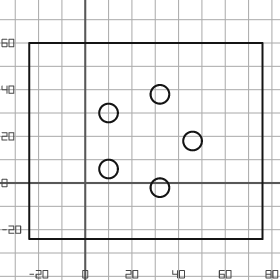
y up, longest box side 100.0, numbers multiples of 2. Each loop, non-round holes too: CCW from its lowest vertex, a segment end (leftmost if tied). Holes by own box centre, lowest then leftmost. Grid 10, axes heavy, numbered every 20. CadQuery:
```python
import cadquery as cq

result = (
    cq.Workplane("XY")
    .moveTo(-24.0, -24.0)
    .lineTo(76.0, -24.0)
    .lineTo(76.0, 60.0)
    .lineTo(-24.0, 60.0)
    .close()
    .moveTo(32.0, -2.0)
    .circle(4.0)
    .moveTo(10.0, 6.0)
    .circle(4.0)
    .moveTo(46.0, 18.0)
    .circle(4.0)
    .moveTo(10.0, 30.0)
    .circle(4.0)
    .moveTo(32.0, 38.0)
    .circle(4.0)
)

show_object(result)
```